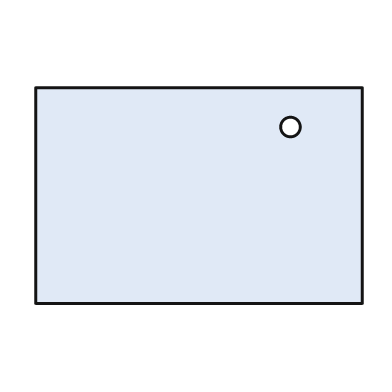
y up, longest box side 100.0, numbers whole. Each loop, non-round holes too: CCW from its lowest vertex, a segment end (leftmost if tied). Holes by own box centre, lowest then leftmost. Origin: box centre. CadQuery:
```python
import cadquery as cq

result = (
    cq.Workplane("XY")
    .moveTo(-50.0, -33.0)
    .lineTo(50.0, -33.0)
    .lineTo(50.0, 33.0)
    .lineTo(-50.0, 33.0)
    .close()
    .moveTo(28.0, 21.0)
    .circle(3.0)
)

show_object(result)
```